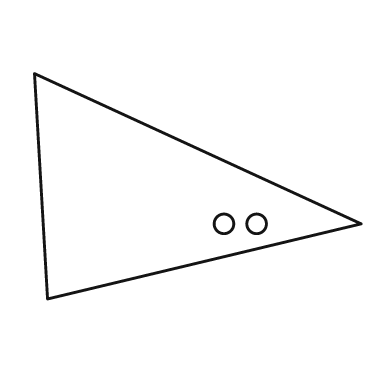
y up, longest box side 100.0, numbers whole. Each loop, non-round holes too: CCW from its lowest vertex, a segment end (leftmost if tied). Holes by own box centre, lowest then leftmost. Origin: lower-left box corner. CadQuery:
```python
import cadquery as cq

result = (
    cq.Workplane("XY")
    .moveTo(4.0, 0.0)
    .lineTo(100.0, 23.0)
    .lineTo(0.0, 69.0)
    .close()
    .moveTo(58.0, 23.0)
    .circle(3.0)
    .moveTo(68.0, 23.0)
    .circle(3.0)
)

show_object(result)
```